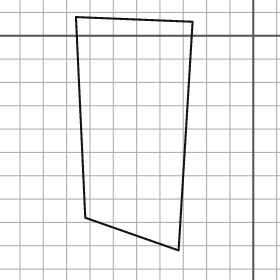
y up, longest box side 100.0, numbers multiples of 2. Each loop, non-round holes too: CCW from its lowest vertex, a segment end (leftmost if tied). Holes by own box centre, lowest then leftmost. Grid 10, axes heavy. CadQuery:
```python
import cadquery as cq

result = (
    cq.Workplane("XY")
    .moveTo(-32.0, -92.0)
    .lineTo(-26.0, 6.0)
    .lineTo(-76.0, 8.0)
    .lineTo(-72.0, -78.0)
    .close()
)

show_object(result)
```